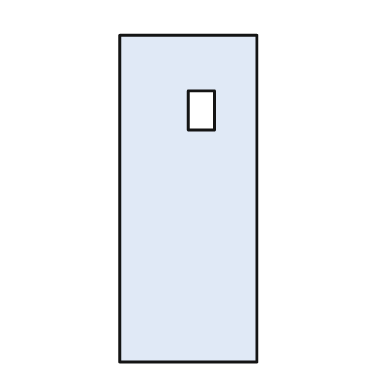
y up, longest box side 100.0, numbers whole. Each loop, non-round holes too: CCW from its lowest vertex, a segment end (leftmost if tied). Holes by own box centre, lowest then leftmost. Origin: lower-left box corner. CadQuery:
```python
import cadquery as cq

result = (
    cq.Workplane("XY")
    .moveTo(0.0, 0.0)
    .lineTo(42.0, 0.0)
    .lineTo(42.0, 100.0)
    .lineTo(0.0, 100.0)
    .close()
    .moveTo(21.0, 71.0)
    .lineTo(29.0, 71.0)
    .lineTo(29.0, 83.0)
    .lineTo(21.0, 83.0)
    .close()
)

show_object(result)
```